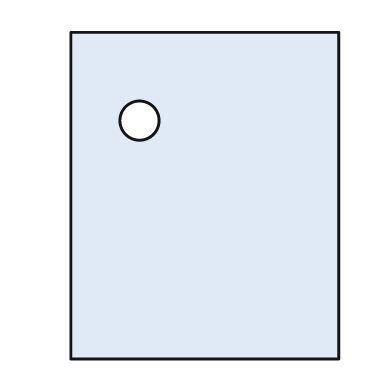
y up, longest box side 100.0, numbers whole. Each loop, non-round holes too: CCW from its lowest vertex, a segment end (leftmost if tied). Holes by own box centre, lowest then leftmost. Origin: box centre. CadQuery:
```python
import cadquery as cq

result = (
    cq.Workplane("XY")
    .moveTo(-41.0, -50.0)
    .lineTo(41.0, -50.0)
    .lineTo(41.0, 50.0)
    .lineTo(-41.0, 50.0)
    .close()
    .moveTo(-20.0, 23.0)
    .circle(6.0)
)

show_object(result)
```